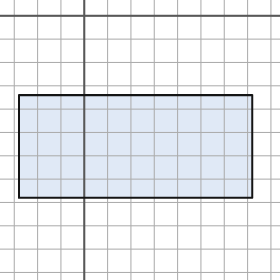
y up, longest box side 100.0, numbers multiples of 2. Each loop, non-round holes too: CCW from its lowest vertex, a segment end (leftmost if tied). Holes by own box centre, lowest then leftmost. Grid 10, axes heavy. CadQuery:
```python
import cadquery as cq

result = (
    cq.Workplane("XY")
    .moveTo(-28.0, -78.0)
    .lineTo(72.0, -78.0)
    .lineTo(72.0, -34.0)
    .lineTo(-28.0, -34.0)
    .close()
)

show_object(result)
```